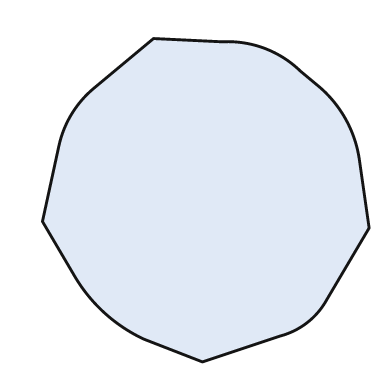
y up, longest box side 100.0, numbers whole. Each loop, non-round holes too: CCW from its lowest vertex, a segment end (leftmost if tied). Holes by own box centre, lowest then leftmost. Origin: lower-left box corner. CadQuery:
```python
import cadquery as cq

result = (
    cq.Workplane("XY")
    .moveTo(49.0, 0.0)
    .lineTo(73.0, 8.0)
    .threePointArc((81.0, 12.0), (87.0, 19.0))
    .lineTo(100.0, 41.0)
    .lineTo(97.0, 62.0)
    .threePointArc((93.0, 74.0), (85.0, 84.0))
    .lineTo(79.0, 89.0)
    .threePointArc((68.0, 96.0), (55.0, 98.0))
    .lineTo(34.0, 99.0)
    .lineTo(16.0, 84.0)
    .threePointArc((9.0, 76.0), (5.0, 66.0))
    .lineTo(0.0, 43.0)
    .lineTo(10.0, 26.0)
    .threePointArc((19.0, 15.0), (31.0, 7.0))
    .close()
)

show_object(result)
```